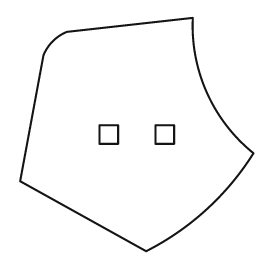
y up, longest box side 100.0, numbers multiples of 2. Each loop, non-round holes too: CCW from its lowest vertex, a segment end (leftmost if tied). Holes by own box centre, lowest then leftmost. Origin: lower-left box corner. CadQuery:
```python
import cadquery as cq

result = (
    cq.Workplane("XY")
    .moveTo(54.0, 0.0)
    .threePointArc((80.0, 18.0), (100.0, 42.0))
    .threePointArc((80.0, 68.0), (74.0, 100.0))
    .lineTo(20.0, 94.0)
    .threePointArc((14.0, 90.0), (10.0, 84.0))
    .lineTo(0.0, 30.0)
    .close()
    .moveTo(34.0, 46.0)
    .lineTo(42.0, 46.0)
    .lineTo(42.0, 54.0)
    .lineTo(34.0, 54.0)
    .close()
    .moveTo(58.0, 46.0)
    .lineTo(66.0, 46.0)
    .lineTo(66.0, 54.0)
    .lineTo(58.0, 54.0)
    .close()
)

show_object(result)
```